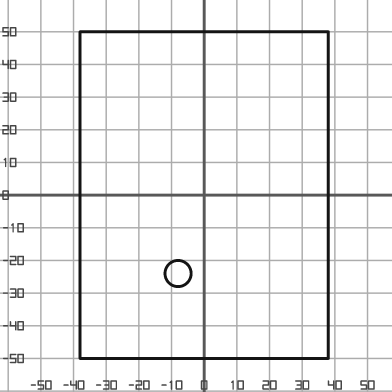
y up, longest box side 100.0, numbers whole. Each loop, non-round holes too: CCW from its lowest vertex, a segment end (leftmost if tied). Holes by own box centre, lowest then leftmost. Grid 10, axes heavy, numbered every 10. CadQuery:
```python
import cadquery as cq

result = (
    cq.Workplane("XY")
    .moveTo(-38.0, -50.0)
    .lineTo(38.0, -50.0)
    .lineTo(38.0, 50.0)
    .lineTo(-38.0, 50.0)
    .close()
    .moveTo(-8.0, -24.0)
    .circle(4.0)
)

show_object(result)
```